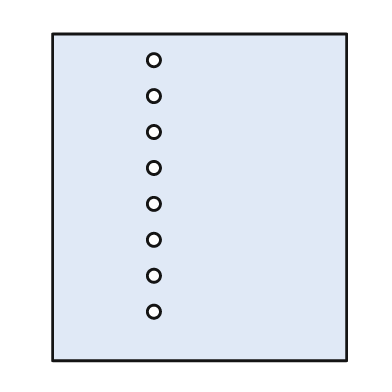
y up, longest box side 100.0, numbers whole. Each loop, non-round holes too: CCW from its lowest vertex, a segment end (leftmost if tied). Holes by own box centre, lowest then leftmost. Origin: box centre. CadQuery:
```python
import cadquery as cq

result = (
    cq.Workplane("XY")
    .moveTo(-45.0, -50.0)
    .lineTo(45.0, -50.0)
    .lineTo(45.0, 50.0)
    .lineTo(-45.0, 50.0)
    .close()
    .moveTo(-14.0, -35.0)
    .circle(2.0)
    .moveTo(-14.0, -24.0)
    .circle(2.0)
    .moveTo(-14.0, -13.0)
    .circle(2.0)
    .moveTo(-14.0, -2.0)
    .circle(2.0)
    .moveTo(-14.0, 9.0)
    .circle(2.0)
    .moveTo(-14.0, 20.0)
    .circle(2.0)
    .moveTo(-14.0, 31.0)
    .circle(2.0)
    .moveTo(-14.0, 42.0)
    .circle(2.0)
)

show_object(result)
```